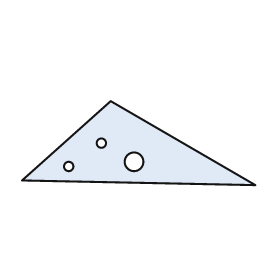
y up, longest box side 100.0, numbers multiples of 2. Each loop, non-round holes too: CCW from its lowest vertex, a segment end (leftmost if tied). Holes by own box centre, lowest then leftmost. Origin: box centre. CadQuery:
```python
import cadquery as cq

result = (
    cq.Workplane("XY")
    .moveTo(50.0, -18.0)
    .lineTo(-12.0, 18.0)
    .lineTo(-50.0, -16.0)
    .close()
    .moveTo(-30.0, -10.0)
    .circle(2.0)
    .moveTo(-2.0, -8.0)
    .circle(4.0)
    .moveTo(-16.0, 0.0)
    .circle(2.0)
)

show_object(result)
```